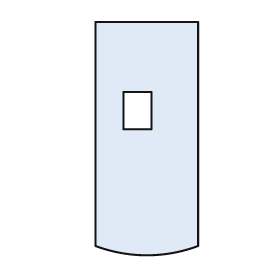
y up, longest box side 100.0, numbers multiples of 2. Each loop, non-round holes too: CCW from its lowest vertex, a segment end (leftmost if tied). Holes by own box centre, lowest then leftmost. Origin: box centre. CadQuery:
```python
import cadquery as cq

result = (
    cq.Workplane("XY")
    .moveTo(-22.0, -46.0)
    .threePointArc((0.0, -50.0), (22.0, -46.0))
    .lineTo(22.0, 50.0)
    .lineTo(-22.0, 50.0)
    .close()
    .moveTo(-10.0, 4.0)
    .lineTo(2.0, 4.0)
    .lineTo(2.0, 20.0)
    .lineTo(-10.0, 20.0)
    .close()
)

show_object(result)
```